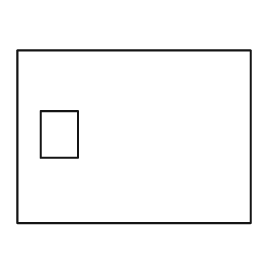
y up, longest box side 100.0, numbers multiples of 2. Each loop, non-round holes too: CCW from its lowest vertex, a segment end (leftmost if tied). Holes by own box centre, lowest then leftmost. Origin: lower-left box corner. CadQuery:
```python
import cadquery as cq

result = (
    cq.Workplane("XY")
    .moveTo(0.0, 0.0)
    .lineTo(100.0, 0.0)
    .lineTo(100.0, 74.0)
    .lineTo(0.0, 74.0)
    .close()
    .moveTo(10.0, 28.0)
    .lineTo(26.0, 28.0)
    .lineTo(26.0, 48.0)
    .lineTo(10.0, 48.0)
    .close()
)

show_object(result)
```